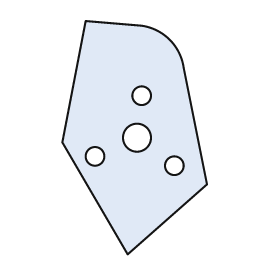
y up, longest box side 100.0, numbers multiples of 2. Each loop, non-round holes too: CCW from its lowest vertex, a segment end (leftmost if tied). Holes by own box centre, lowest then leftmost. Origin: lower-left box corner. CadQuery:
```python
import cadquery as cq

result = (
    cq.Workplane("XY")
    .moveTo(28.0, 0.0)
    .lineTo(62.0, 30.0)
    .lineTo(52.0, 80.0)
    .threePointArc((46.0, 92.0), (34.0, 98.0))
    .lineTo(10.0, 100.0)
    .lineTo(0.0, 48.0)
    .close()
    .moveTo(48.0, 38.0)
    .circle(4.0)
    .moveTo(14.0, 42.0)
    .circle(4.0)
    .moveTo(32.0, 50.0)
    .circle(6.0)
    .moveTo(34.0, 68.0)
    .circle(4.0)
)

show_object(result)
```